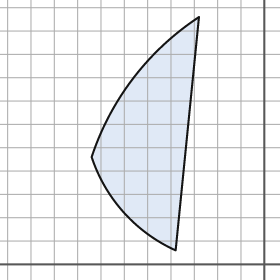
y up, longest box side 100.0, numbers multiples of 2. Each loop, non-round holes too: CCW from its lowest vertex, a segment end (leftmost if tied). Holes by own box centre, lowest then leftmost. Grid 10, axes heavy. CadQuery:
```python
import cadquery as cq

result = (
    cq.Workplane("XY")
    .moveTo(-38.0, 6.0)
    .lineTo(-28.0, 106.0)
    .threePointArc((-56.0, 80.0), (-74.0, 46.0))
    .threePointArc((-60.0, 22.0), (-38.0, 6.0))
    .close()
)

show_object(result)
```